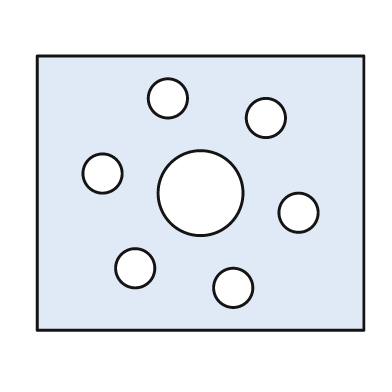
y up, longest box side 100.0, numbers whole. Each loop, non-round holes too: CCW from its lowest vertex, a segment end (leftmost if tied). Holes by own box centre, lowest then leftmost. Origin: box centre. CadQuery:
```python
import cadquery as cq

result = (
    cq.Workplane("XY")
    .moveTo(-50.0, -42.0)
    .lineTo(50.0, -42.0)
    .lineTo(50.0, 42.0)
    .lineTo(-50.0, 42.0)
    .close()
    .moveTo(10.0, -29.0)
    .circle(6.0)
    .moveTo(-20.0, -23.0)
    .circle(6.0)
    .moveTo(30.0, -6.0)
    .circle(6.0)
    .moveTo(0.0, 0.0)
    .circle(13.0)
    .moveTo(-30.0, 6.0)
    .circle(6.0)
    .moveTo(20.0, 23.0)
    .circle(6.0)
    .moveTo(-10.0, 29.0)
    .circle(6.0)
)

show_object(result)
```